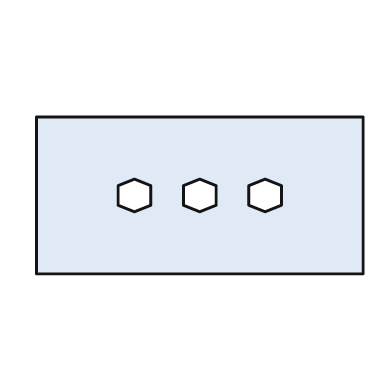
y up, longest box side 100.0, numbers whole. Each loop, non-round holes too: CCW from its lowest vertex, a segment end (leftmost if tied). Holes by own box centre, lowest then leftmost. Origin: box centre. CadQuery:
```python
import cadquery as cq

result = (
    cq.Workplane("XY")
    .moveTo(-50.0, -24.0)
    .lineTo(50.0, -24.0)
    .lineTo(50.0, 24.0)
    .lineTo(-50.0, 24.0)
    .close()
    .moveTo(-20.0, -5.0)
    .lineTo(-15.0, -3.0)
    .lineTo(-15.0, 3.0)
    .lineTo(-20.0, 5.0)
    .lineTo(-25.0, 3.0)
    .lineTo(-25.0, -3.0)
    .close()
    .moveTo(0.0, -5.0)
    .lineTo(5.0, -3.0)
    .lineTo(5.0, 3.0)
    .lineTo(0.0, 5.0)
    .lineTo(-5.0, 3.0)
    .lineTo(-5.0, -3.0)
    .close()
    .moveTo(20.0, -5.0)
    .lineTo(25.0, -3.0)
    .lineTo(25.0, 3.0)
    .lineTo(20.0, 5.0)
    .lineTo(15.0, 3.0)
    .lineTo(15.0, -3.0)
    .close()
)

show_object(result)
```